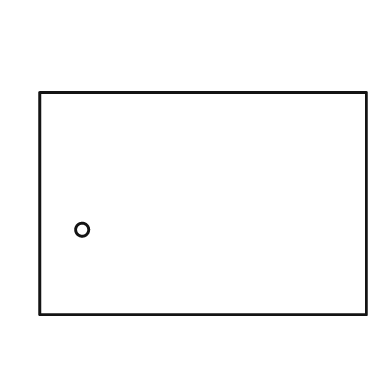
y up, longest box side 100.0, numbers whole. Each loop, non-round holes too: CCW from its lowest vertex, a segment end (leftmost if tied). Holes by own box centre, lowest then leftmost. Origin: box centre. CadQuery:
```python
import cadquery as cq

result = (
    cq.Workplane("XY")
    .moveTo(-50.0, -34.0)
    .lineTo(50.0, -34.0)
    .lineTo(50.0, 34.0)
    .lineTo(-50.0, 34.0)
    .close()
    .moveTo(-37.0, -8.0)
    .circle(2.0)
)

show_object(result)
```